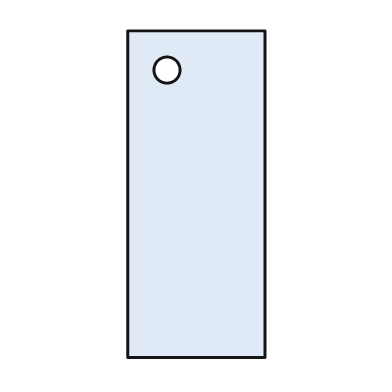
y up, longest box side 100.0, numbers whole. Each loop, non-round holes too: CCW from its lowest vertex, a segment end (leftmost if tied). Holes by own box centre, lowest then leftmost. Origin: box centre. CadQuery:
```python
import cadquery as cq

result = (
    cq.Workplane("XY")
    .moveTo(-21.0, -50.0)
    .lineTo(21.0, -50.0)
    .lineTo(21.0, 50.0)
    .lineTo(-21.0, 50.0)
    .close()
    .moveTo(-9.0, 38.0)
    .circle(4.0)
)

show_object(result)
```